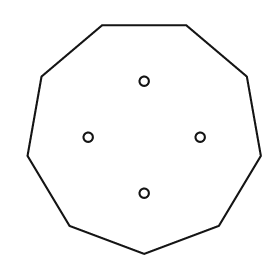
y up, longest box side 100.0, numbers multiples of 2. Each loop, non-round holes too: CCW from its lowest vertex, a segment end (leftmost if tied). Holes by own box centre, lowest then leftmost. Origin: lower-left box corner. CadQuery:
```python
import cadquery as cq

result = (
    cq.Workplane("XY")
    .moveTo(50.0, 0.0)
    .lineTo(82.0, 12.0)
    .lineTo(100.0, 42.0)
    .lineTo(94.0, 76.0)
    .lineTo(68.0, 98.0)
    .lineTo(32.0, 98.0)
    .lineTo(6.0, 76.0)
    .lineTo(0.0, 42.0)
    .lineTo(18.0, 12.0)
    .close()
    .moveTo(50.0, 26.0)
    .circle(2.0)
    .moveTo(26.0, 50.0)
    .circle(2.0)
    .moveTo(74.0, 50.0)
    .circle(2.0)
    .moveTo(50.0, 74.0)
    .circle(2.0)
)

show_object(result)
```